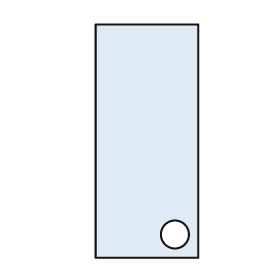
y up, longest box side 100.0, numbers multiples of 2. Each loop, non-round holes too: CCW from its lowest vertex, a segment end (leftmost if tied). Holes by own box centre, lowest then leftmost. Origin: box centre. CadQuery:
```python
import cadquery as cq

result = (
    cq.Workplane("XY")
    .moveTo(-22.0, -50.0)
    .lineTo(22.0, -50.0)
    .lineTo(22.0, 50.0)
    .lineTo(-22.0, 50.0)
    .close()
    .moveTo(12.0, -40.0)
    .circle(6.0)
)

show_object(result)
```